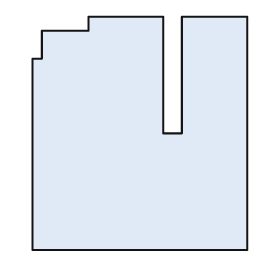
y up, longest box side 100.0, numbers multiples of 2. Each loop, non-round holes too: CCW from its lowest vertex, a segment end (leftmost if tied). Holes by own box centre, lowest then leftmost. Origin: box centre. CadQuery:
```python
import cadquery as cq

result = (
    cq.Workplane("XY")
    .moveTo(-46.0, -50.0)
    .lineTo(46.0, -50.0)
    .lineTo(46.0, 50.0)
    .lineTo(18.0, 50.0)
    .lineTo(18.0, 0.0)
    .lineTo(10.0, 0.0)
    .lineTo(10.0, 50.0)
    .lineTo(-22.0, 50.0)
    .lineTo(-22.0, 44.0)
    .lineTo(-42.0, 44.0)
    .lineTo(-42.0, 32.0)
    .lineTo(-46.0, 32.0)
    .close()
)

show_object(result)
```